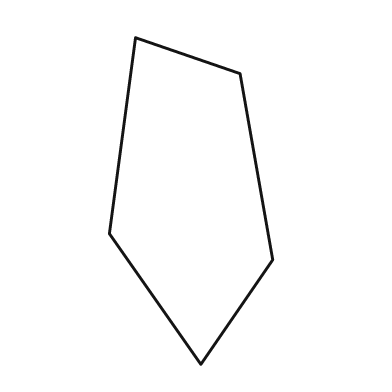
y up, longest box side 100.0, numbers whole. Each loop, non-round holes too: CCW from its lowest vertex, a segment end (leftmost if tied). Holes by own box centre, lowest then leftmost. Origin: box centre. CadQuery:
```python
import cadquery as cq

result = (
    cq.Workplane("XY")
    .moveTo(3.0, -50.0)
    .lineTo(25.0, -18.0)
    .lineTo(15.0, 39.0)
    .lineTo(-17.0, 50.0)
    .lineTo(-25.0, -10.0)
    .close()
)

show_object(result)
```